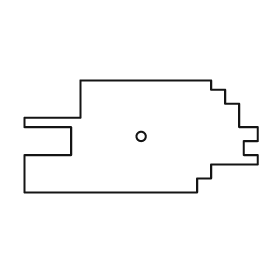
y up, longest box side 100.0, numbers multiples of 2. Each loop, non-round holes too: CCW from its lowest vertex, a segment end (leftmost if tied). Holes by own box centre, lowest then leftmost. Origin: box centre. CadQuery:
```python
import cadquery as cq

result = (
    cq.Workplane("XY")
    .moveTo(-50.0, -24.0)
    .lineTo(24.0, -24.0)
    .lineTo(24.0, -18.0)
    .lineTo(30.0, -18.0)
    .lineTo(30.0, -12.0)
    .lineTo(50.0, -12.0)
    .lineTo(50.0, -8.0)
    .lineTo(44.0, -8.0)
    .lineTo(44.0, -2.0)
    .lineTo(50.0, -2.0)
    .lineTo(50.0, 4.0)
    .lineTo(42.0, 4.0)
    .lineTo(42.0, 14.0)
    .lineTo(36.0, 14.0)
    .lineTo(36.0, 20.0)
    .lineTo(30.0, 20.0)
    .lineTo(30.0, 24.0)
    .lineTo(-26.0, 24.0)
    .lineTo(-26.0, 8.0)
    .lineTo(-50.0, 8.0)
    .lineTo(-50.0, 4.0)
    .lineTo(-30.0, 4.0)
    .lineTo(-30.0, -8.0)
    .lineTo(-50.0, -8.0)
    .close()
    .moveTo(0.0, 0.0)
    .circle(2.0)
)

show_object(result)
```